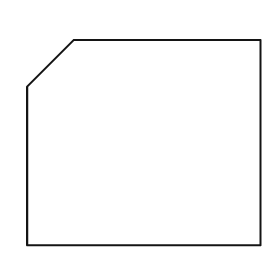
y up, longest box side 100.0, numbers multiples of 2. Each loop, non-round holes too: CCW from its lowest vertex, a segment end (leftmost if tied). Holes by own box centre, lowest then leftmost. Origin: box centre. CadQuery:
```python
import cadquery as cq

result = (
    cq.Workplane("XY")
    .moveTo(-50.0, -44.0)
    .lineTo(50.0, -44.0)
    .lineTo(50.0, 44.0)
    .lineTo(-30.0, 44.0)
    .lineTo(-50.0, 24.0)
    .close()
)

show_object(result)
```